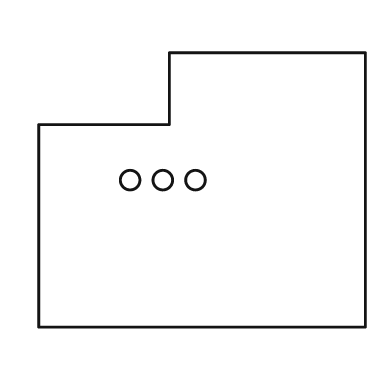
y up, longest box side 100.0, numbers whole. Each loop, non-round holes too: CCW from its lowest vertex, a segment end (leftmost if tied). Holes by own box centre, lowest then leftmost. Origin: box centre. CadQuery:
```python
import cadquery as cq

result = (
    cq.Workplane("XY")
    .moveTo(-50.0, -42.0)
    .lineTo(50.0, -42.0)
    .lineTo(50.0, 42.0)
    .lineTo(-10.0, 42.0)
    .lineTo(-10.0, 20.0)
    .lineTo(-50.0, 20.0)
    .close()
    .moveTo(-22.0, 3.0)
    .circle(3.0)
    .moveTo(-12.0, 3.0)
    .circle(3.0)
    .moveTo(-2.0, 3.0)
    .circle(3.0)
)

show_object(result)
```